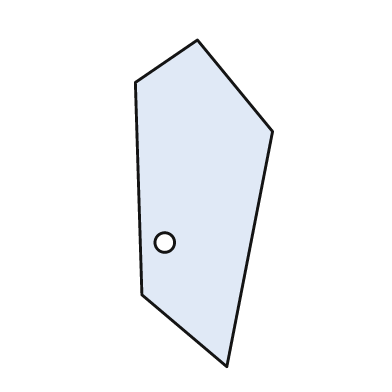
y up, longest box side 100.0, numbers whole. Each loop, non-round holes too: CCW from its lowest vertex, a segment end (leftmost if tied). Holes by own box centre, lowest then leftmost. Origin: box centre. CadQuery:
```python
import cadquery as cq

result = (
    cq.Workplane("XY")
    .moveTo(7.0, -50.0)
    .lineTo(21.0, 22.0)
    .lineTo(-2.0, 50.0)
    .lineTo(-21.0, 37.0)
    .lineTo(-19.0, -28.0)
    .close()
    .moveTo(-12.0, -12.0)
    .circle(3.0)
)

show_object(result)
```